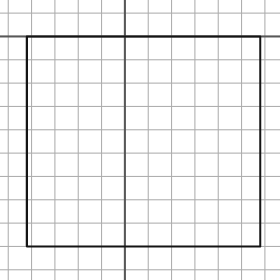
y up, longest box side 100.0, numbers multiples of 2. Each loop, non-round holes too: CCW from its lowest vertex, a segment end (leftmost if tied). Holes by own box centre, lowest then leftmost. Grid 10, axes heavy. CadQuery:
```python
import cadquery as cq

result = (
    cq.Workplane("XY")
    .moveTo(-42.0, -90.0)
    .lineTo(58.0, -90.0)
    .lineTo(58.0, 0.0)
    .lineTo(-42.0, 0.0)
    .close()
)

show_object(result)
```